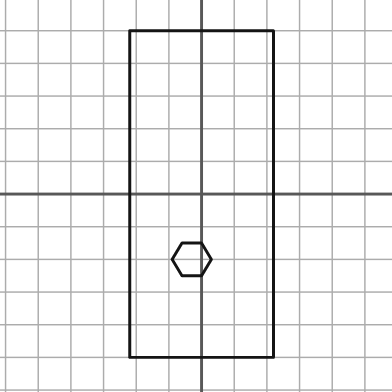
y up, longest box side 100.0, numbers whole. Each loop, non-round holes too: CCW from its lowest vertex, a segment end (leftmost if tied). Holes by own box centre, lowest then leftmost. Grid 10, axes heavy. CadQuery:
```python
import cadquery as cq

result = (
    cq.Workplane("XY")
    .moveTo(-22.0, -50.0)
    .lineTo(22.0, -50.0)
    .lineTo(22.0, 50.0)
    .lineTo(-22.0, 50.0)
    .close()
    .moveTo(-6.0, -25.0)
    .lineTo(0.0, -25.0)
    .lineTo(3.0, -20.0)
    .lineTo(0.0, -15.0)
    .lineTo(-6.0, -15.0)
    .lineTo(-9.0, -20.0)
    .close()
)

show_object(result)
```